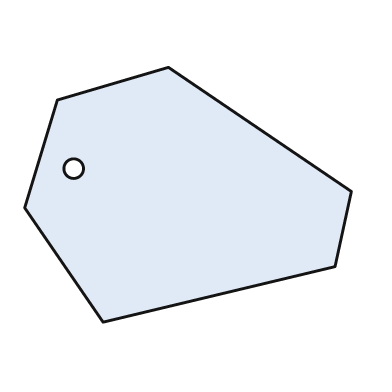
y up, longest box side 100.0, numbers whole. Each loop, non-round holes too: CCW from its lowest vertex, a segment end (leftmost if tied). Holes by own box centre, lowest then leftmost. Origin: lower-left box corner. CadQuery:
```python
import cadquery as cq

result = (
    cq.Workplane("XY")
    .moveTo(24.0, 0.0)
    .lineTo(95.0, 17.0)
    .lineTo(100.0, 40.0)
    .lineTo(44.0, 78.0)
    .lineTo(10.0, 68.0)
    .lineTo(0.0, 35.0)
    .close()
    .moveTo(15.0, 47.0)
    .circle(3.0)
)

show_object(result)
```